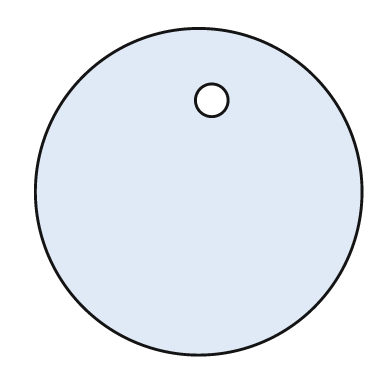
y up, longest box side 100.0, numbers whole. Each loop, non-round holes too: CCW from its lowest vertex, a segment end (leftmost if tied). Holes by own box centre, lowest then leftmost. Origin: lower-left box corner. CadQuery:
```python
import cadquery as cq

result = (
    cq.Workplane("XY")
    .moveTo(50.0, 50.0)
    .circle(50.0)
    .moveTo(54.0, 78.0)
    .circle(5.0)
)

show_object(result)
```